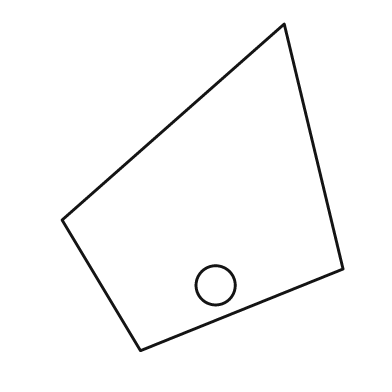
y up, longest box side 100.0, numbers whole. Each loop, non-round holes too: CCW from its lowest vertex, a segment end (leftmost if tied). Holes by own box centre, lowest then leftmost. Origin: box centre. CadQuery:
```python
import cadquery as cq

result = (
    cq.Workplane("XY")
    .moveTo(-19.0, -50.0)
    .lineTo(43.0, -25.0)
    .lineTo(25.0, 50.0)
    .lineTo(-43.0, -10.0)
    .close()
    .moveTo(4.0, -30.0)
    .circle(6.0)
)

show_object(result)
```